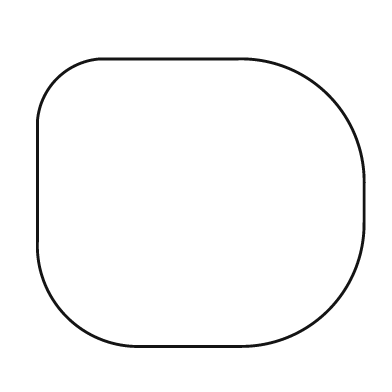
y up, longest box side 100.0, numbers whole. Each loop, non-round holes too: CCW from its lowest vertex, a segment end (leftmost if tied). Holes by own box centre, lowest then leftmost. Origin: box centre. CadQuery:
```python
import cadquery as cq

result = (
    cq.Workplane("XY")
    .moveTo(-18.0, -44.0)
    .lineTo(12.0, -44.0)
    .threePointArc((39.0, -33.0), (50.0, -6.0))
    .lineTo(50.0, 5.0)
    .threePointArc((39.0, 33.0), (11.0, 44.0))
    .lineTo(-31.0, 44.0)
    .threePointArc((-44.0, 38.0), (-50.0, 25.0))
    .lineTo(-50.0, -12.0)
    .threePointArc((-41.0, -35.0), (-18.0, -44.0))
    .close()
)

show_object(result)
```